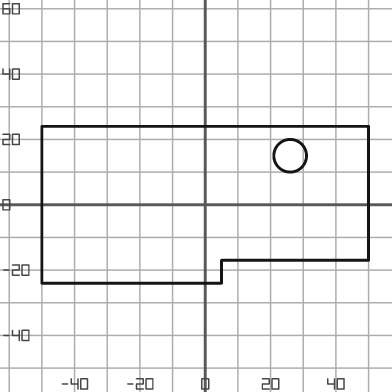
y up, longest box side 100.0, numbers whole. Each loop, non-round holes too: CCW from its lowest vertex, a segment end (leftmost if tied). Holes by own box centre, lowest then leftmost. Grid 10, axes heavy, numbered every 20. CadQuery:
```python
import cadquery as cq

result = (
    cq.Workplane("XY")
    .moveTo(-50.0, -24.0)
    .lineTo(5.0, -24.0)
    .lineTo(5.0, -17.0)
    .lineTo(50.0, -17.0)
    .lineTo(50.0, 24.0)
    .lineTo(-50.0, 24.0)
    .close()
    .moveTo(26.0, 15.0)
    .circle(5.0)
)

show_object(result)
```